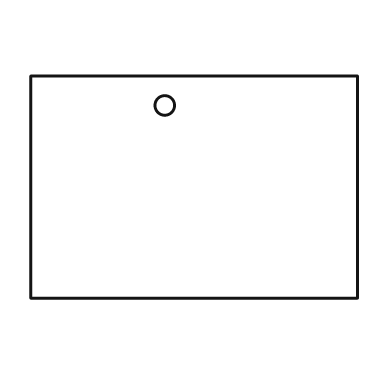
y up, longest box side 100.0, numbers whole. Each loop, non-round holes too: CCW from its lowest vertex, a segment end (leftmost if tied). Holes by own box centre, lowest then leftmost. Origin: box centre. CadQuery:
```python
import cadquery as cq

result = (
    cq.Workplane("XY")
    .moveTo(-50.0, -34.0)
    .lineTo(50.0, -34.0)
    .lineTo(50.0, 34.0)
    .lineTo(-50.0, 34.0)
    .close()
    .moveTo(-9.0, 25.0)
    .circle(3.0)
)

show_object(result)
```